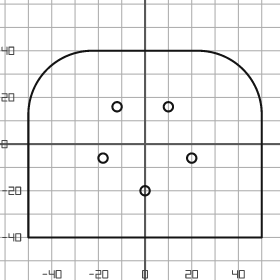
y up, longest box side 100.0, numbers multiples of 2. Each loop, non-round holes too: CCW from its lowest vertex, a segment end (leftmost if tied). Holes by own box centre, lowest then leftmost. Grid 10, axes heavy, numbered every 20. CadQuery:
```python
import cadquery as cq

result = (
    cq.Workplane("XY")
    .moveTo(-50.0, -40.0)
    .lineTo(50.0, -40.0)
    .lineTo(50.0, 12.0)
    .threePointArc((42.0, 32.0), (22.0, 40.0))
    .lineTo(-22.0, 40.0)
    .threePointArc((-42.0, 32.0), (-50.0, 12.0))
    .close()
    .moveTo(0.0, -20.0)
    .circle(2.0)
    .moveTo(-18.0, -6.0)
    .circle(2.0)
    .moveTo(20.0, -6.0)
    .circle(2.0)
    .moveTo(-12.0, 16.0)
    .circle(2.0)
    .moveTo(10.0, 16.0)
    .circle(2.0)
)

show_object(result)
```